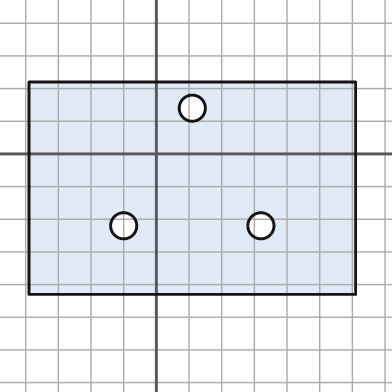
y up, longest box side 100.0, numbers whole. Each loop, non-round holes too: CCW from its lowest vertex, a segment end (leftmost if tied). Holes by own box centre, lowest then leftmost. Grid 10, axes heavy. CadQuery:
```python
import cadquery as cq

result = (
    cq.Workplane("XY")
    .moveTo(-39.0, -43.0)
    .lineTo(61.0, -43.0)
    .lineTo(61.0, 22.0)
    .lineTo(-39.0, 22.0)
    .close()
    .moveTo(-10.0, -22.0)
    .circle(4.0)
    .moveTo(32.0, -22.0)
    .circle(4.0)
    .moveTo(11.0, 14.0)
    .circle(4.0)
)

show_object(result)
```